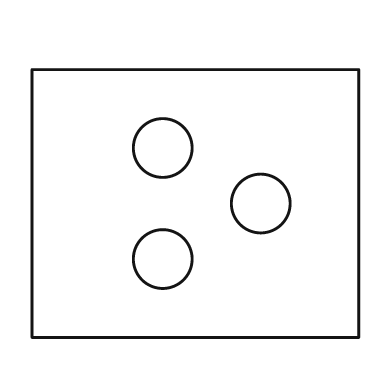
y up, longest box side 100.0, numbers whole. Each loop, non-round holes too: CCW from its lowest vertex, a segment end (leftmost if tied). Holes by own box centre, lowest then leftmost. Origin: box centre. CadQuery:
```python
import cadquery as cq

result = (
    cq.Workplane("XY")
    .moveTo(-50.0, -41.0)
    .lineTo(50.0, -41.0)
    .lineTo(50.0, 41.0)
    .lineTo(-50.0, 41.0)
    .close()
    .moveTo(-10.0, -17.0)
    .circle(9.0)
    .moveTo(20.0, 0.0)
    .circle(9.0)
    .moveTo(-10.0, 17.0)
    .circle(9.0)
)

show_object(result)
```